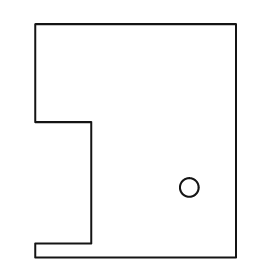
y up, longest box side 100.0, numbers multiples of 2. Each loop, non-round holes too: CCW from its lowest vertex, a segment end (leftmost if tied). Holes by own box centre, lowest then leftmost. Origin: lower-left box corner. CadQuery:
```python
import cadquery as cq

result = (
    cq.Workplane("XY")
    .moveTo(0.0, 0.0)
    .lineTo(86.0, 0.0)
    .lineTo(86.0, 100.0)
    .lineTo(0.0, 100.0)
    .lineTo(0.0, 58.0)
    .lineTo(24.0, 58.0)
    .lineTo(24.0, 6.0)
    .lineTo(0.0, 6.0)
    .close()
    .moveTo(66.0, 30.0)
    .circle(4.0)
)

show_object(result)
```